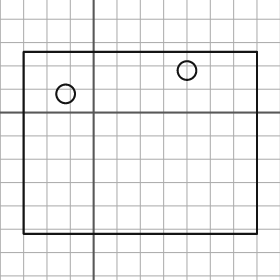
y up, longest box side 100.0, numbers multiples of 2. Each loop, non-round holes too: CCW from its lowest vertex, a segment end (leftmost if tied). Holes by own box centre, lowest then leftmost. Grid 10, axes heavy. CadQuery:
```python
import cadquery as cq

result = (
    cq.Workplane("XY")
    .moveTo(-30.0, -52.0)
    .lineTo(70.0, -52.0)
    .lineTo(70.0, 26.0)
    .lineTo(-30.0, 26.0)
    .close()
    .moveTo(-12.0, 8.0)
    .circle(4.0)
    .moveTo(40.0, 18.0)
    .circle(4.0)
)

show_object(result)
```